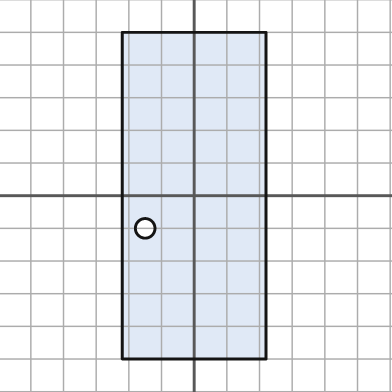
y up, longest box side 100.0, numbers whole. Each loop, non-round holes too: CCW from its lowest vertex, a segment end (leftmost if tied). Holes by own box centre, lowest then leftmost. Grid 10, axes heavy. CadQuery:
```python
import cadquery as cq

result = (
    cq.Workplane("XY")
    .moveTo(-22.0, -50.0)
    .lineTo(22.0, -50.0)
    .lineTo(22.0, 50.0)
    .lineTo(-22.0, 50.0)
    .close()
    .moveTo(-15.0, -10.0)
    .circle(3.0)
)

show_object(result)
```